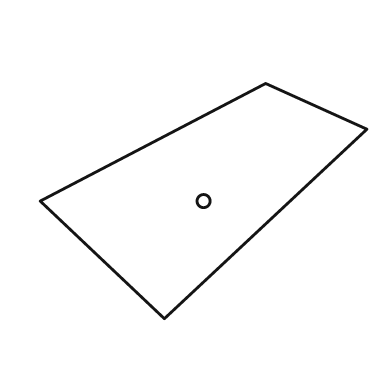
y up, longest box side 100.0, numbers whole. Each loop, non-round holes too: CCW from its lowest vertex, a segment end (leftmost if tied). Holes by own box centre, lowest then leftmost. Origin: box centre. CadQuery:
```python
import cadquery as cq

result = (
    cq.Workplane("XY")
    .moveTo(-12.0, -36.0)
    .lineTo(50.0, 22.0)
    .lineTo(19.0, 36.0)
    .lineTo(-50.0, 0.0)
    .close()
    .moveTo(0.0, 0.0)
    .circle(2.0)
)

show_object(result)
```